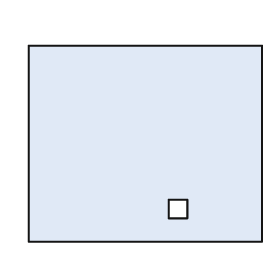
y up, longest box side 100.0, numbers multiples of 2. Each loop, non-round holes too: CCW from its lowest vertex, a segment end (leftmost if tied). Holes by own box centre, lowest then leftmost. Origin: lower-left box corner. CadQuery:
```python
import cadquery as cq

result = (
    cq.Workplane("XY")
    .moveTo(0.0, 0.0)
    .lineTo(100.0, 0.0)
    .lineTo(100.0, 84.0)
    .lineTo(0.0, 84.0)
    .close()
    .moveTo(60.0, 10.0)
    .lineTo(68.0, 10.0)
    .lineTo(68.0, 18.0)
    .lineTo(60.0, 18.0)
    .close()
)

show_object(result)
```